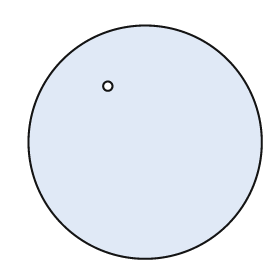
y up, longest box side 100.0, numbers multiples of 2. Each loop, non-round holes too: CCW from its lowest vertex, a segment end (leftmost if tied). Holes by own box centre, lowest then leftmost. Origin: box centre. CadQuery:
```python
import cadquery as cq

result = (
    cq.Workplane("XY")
    .moveTo(0.0, 0.0)
    .circle(50.0)
    .moveTo(-16.0, 24.0)
    .circle(2.0)
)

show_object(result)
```